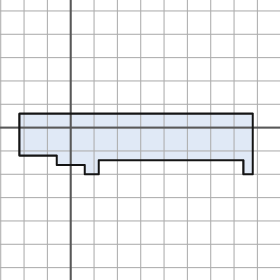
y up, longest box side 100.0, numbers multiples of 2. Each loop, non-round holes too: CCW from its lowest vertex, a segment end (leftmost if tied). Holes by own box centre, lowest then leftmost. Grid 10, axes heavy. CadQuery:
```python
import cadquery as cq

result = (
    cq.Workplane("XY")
    .moveTo(6.0, -20.0)
    .lineTo(12.0, -20.0)
    .lineTo(12.0, -14.0)
    .lineTo(74.0, -14.0)
    .lineTo(74.0, -20.0)
    .lineTo(78.0, -20.0)
    .lineTo(78.0, 6.0)
    .lineTo(-22.0, 6.0)
    .lineTo(-22.0, -12.0)
    .lineTo(-6.0, -12.0)
    .lineTo(-6.0, -16.0)
    .lineTo(6.0, -16.0)
    .close()
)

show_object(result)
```